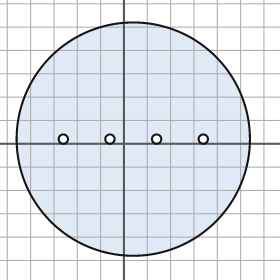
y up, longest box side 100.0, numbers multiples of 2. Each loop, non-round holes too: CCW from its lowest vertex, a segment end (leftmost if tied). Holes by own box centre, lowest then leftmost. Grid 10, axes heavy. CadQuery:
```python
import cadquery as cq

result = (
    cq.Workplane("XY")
    .moveTo(4.0, 2.0)
    .circle(50.0)
    .moveTo(-26.0, 2.0)
    .circle(2.0)
    .moveTo(-6.0, 2.0)
    .circle(2.0)
    .moveTo(14.0, 2.0)
    .circle(2.0)
    .moveTo(34.0, 2.0)
    .circle(2.0)
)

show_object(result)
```